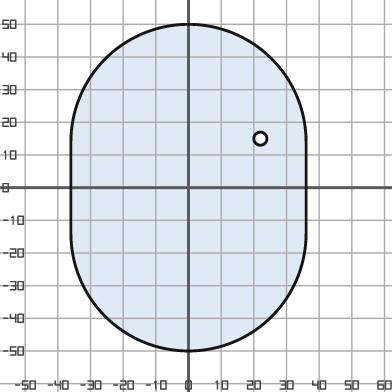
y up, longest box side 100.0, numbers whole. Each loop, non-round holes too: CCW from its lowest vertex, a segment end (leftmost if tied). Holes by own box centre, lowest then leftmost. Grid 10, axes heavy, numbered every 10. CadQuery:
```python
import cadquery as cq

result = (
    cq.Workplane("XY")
    .moveTo(-36.0, -14.0)
    .threePointArc((0.0, -50.0), (36.0, -14.0))
    .lineTo(36.0, 14.0)
    .threePointArc((0.0, 50.0), (-36.0, 14.0))
    .close()
    .moveTo(22.0, 15.0)
    .circle(2.0)
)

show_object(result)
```